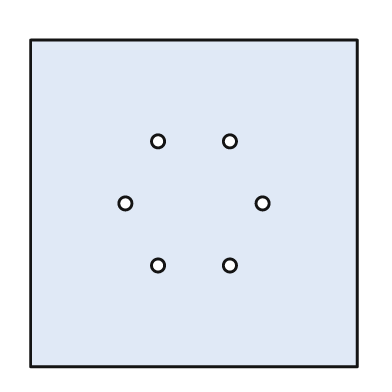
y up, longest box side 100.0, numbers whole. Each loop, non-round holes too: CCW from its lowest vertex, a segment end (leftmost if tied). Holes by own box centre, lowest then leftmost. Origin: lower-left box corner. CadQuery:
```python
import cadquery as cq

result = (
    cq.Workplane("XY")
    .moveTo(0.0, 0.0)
    .lineTo(100.0, 0.0)
    .lineTo(100.0, 100.0)
    .lineTo(0.0, 100.0)
    .close()
    .moveTo(39.0, 31.0)
    .circle(2.0)
    .moveTo(61.0, 31.0)
    .circle(2.0)
    .moveTo(29.0, 50.0)
    .circle(2.0)
    .moveTo(71.0, 50.0)
    .circle(2.0)
    .moveTo(39.0, 69.0)
    .circle(2.0)
    .moveTo(61.0, 69.0)
    .circle(2.0)
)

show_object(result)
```